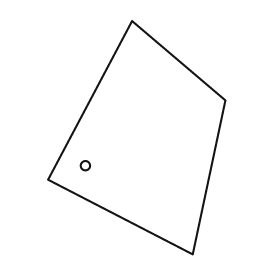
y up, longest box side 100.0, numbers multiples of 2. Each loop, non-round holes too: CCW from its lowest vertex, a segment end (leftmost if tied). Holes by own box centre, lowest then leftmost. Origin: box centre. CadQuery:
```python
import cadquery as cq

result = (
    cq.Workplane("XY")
    .moveTo(24.0, -50.0)
    .lineTo(38.0, 16.0)
    .lineTo(-2.0, 50.0)
    .lineTo(-38.0, -18.0)
    .close()
    .moveTo(-22.0, -12.0)
    .circle(2.0)
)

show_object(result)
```